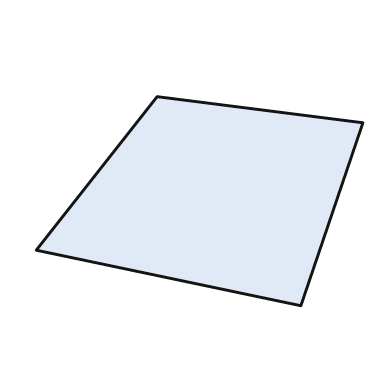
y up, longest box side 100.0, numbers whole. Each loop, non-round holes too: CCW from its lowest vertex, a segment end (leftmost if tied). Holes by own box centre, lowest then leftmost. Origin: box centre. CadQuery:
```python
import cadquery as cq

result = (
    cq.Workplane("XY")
    .moveTo(31.0, -32.0)
    .lineTo(50.0, 24.0)
    .lineTo(-13.0, 32.0)
    .lineTo(-50.0, -15.0)
    .close()
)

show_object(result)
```